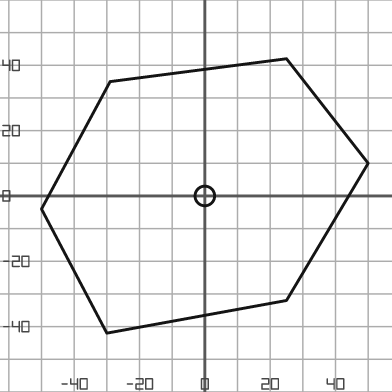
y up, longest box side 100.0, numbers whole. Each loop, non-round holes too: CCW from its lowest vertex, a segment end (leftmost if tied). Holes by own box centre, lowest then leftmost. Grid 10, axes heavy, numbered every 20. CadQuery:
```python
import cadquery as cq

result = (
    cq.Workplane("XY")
    .moveTo(-30.0, -42.0)
    .lineTo(25.0, -32.0)
    .lineTo(50.0, 10.0)
    .lineTo(25.0, 42.0)
    .lineTo(-29.0, 35.0)
    .lineTo(-50.0, -4.0)
    .close()
    .moveTo(0.0, 0.0)
    .circle(3.0)
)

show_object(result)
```